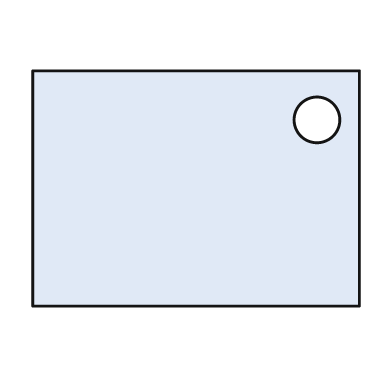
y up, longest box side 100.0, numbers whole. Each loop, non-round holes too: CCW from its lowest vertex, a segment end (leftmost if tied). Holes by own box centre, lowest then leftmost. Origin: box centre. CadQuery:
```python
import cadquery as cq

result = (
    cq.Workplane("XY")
    .moveTo(-50.0, -36.0)
    .lineTo(50.0, -36.0)
    .lineTo(50.0, 36.0)
    .lineTo(-50.0, 36.0)
    .close()
    .moveTo(37.0, 21.0)
    .circle(7.0)
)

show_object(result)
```